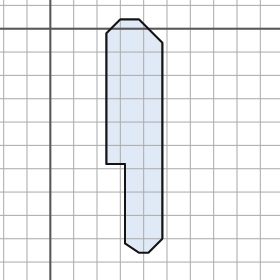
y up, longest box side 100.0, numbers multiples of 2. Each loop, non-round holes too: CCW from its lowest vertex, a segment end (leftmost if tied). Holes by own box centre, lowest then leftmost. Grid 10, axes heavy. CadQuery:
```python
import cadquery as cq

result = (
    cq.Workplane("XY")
    .moveTo(38.0, -96.0)
    .lineTo(42.0, -96.0)
    .lineTo(48.0, -90.0)
    .lineTo(48.0, -6.0)
    .lineTo(38.0, 4.0)
    .lineTo(30.0, 4.0)
    .lineTo(24.0, -2.0)
    .lineTo(24.0, -58.0)
    .lineTo(32.0, -58.0)
    .lineTo(32.0, -92.0)
    .close()
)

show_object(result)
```